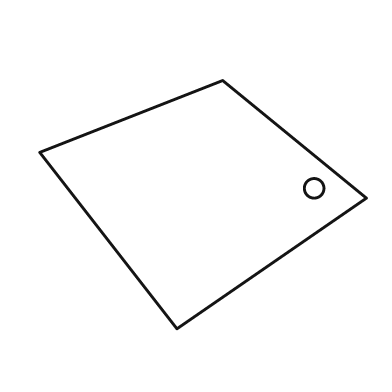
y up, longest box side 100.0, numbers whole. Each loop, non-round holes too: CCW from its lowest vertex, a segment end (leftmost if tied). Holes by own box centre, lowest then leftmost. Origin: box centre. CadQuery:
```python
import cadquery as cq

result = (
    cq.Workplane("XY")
    .moveTo(-8.0, -38.0)
    .lineTo(50.0, 2.0)
    .lineTo(6.0, 38.0)
    .lineTo(-50.0, 16.0)
    .close()
    .moveTo(34.0, 5.0)
    .circle(3.0)
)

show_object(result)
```